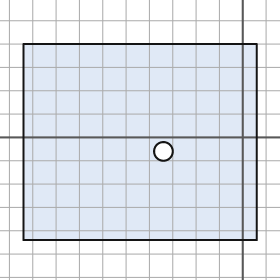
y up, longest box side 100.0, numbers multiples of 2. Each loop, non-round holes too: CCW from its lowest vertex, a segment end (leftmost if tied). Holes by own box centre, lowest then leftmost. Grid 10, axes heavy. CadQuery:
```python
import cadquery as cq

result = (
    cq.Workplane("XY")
    .moveTo(-94.0, -44.0)
    .lineTo(6.0, -44.0)
    .lineTo(6.0, 40.0)
    .lineTo(-94.0, 40.0)
    .close()
    .moveTo(-34.0, -6.0)
    .circle(4.0)
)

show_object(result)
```